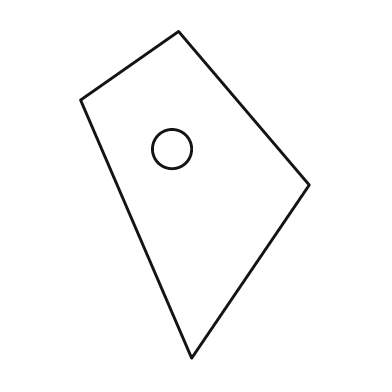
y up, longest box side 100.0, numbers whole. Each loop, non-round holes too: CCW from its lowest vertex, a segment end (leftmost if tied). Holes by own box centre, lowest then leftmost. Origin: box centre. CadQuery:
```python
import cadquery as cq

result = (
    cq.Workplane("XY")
    .moveTo(-1.0, -50.0)
    .lineTo(35.0, 3.0)
    .lineTo(-5.0, 50.0)
    .lineTo(-35.0, 29.0)
    .close()
    .moveTo(-7.0, 14.0)
    .circle(6.0)
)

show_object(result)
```